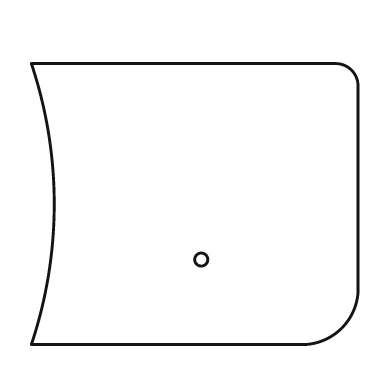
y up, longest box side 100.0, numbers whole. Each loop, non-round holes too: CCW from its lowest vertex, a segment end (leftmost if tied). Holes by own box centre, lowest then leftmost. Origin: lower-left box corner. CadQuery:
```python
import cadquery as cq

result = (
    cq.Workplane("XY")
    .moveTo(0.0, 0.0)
    .lineTo(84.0, 0.0)
    .threePointArc((95.0, 5.0), (100.0, 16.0))
    .lineTo(100.0, 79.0)
    .threePointArc((98.0, 84.0), (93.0, 86.0))
    .lineTo(0.0, 86.0)
    .threePointArc((7.0, 43.0), (0.0, 0.0))
    .close()
    .moveTo(52.0, 26.0)
    .circle(2.0)
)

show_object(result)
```